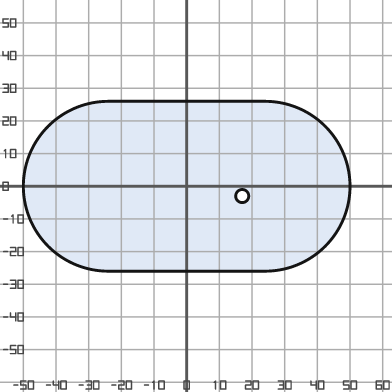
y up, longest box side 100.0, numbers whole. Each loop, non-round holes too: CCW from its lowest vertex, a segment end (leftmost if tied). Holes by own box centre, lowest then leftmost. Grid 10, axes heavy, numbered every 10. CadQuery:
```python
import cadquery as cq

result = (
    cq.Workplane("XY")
    .moveTo(-24.0, -26.0)
    .lineTo(24.0, -26.0)
    .threePointArc((50.0, 0.0), (24.0, 26.0))
    .lineTo(-24.0, 26.0)
    .threePointArc((-50.0, 0.0), (-24.0, -26.0))
    .close()
    .moveTo(17.0, -3.0)
    .circle(2.0)
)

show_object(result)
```